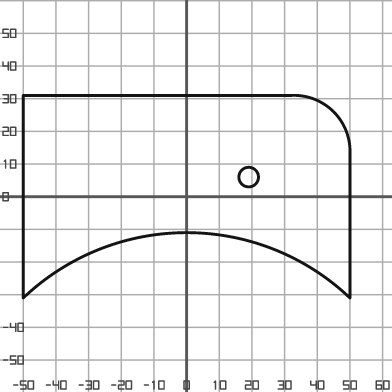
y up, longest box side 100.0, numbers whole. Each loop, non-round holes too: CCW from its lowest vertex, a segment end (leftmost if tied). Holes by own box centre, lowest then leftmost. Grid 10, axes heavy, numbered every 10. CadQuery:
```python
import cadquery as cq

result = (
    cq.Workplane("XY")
    .moveTo(-50.0, -31.0)
    .threePointArc((0.0, -11.0), (50.0, -31.0))
    .lineTo(50.0, 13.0)
    .threePointArc((45.0, 26.0), (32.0, 31.0))
    .lineTo(-50.0, 31.0)
    .close()
    .moveTo(19.0, 6.0)
    .circle(3.0)
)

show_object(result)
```